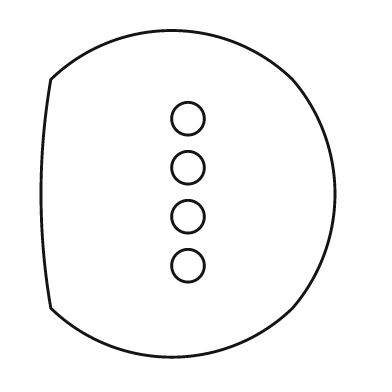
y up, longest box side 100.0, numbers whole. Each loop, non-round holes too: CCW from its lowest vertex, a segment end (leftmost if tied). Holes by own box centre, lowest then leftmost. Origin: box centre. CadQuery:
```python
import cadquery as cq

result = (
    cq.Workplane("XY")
    .moveTo(-42.0, -35.0)
    .threePointArc((-5.0, -50.0), (32.0, -35.0))
    .threePointArc((45.0, 0.0), (32.0, 35.0))
    .threePointArc((-5.0, 50.0), (-42.0, 35.0))
    .threePointArc((-45.0, 0.0), (-42.0, -35.0))
    .close()
    .moveTo(0.0, -22.0)
    .circle(5.0)
    .moveTo(0.0, -7.0)
    .circle(5.0)
    .moveTo(0.0, 8.0)
    .circle(5.0)
    .moveTo(0.0, 23.0)
    .circle(5.0)
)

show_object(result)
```